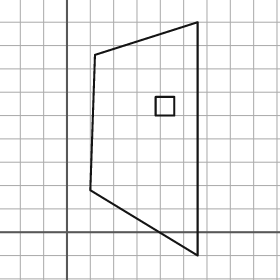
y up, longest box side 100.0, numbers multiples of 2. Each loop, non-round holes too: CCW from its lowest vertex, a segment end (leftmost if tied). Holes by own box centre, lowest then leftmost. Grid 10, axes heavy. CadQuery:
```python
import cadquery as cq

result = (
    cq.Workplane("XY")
    .moveTo(56.0, -10.0)
    .lineTo(56.0, 90.0)
    .lineTo(12.0, 76.0)
    .lineTo(10.0, 18.0)
    .close()
    .moveTo(38.0, 50.0)
    .lineTo(46.0, 50.0)
    .lineTo(46.0, 58.0)
    .lineTo(38.0, 58.0)
    .close()
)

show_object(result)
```